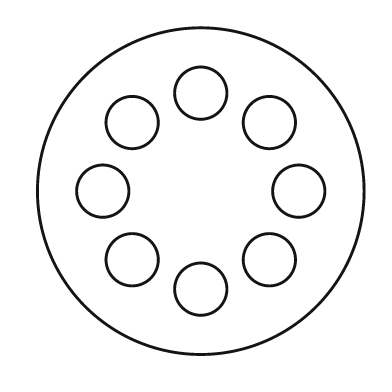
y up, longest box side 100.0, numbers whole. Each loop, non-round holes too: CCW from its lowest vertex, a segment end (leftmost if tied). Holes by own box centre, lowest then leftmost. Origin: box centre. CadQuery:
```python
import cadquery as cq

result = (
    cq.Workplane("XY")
    .moveTo(0.0, 0.0)
    .circle(50.0)
    .moveTo(0.0, -30.0)
    .circle(8.0)
    .moveTo(-21.0, -21.0)
    .circle(8.0)
    .moveTo(21.0, -21.0)
    .circle(8.0)
    .moveTo(-30.0, 0.0)
    .circle(8.0)
    .moveTo(30.0, 0.0)
    .circle(8.0)
    .moveTo(-21.0, 21.0)
    .circle(8.0)
    .moveTo(21.0, 21.0)
    .circle(8.0)
    .moveTo(0.0, 30.0)
    .circle(8.0)
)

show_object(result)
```